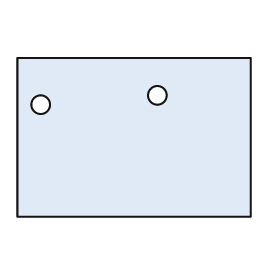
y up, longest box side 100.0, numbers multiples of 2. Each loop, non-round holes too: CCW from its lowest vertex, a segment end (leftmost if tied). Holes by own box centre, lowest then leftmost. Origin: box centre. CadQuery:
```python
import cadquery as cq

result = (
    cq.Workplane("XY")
    .moveTo(-50.0, -34.0)
    .lineTo(50.0, -34.0)
    .lineTo(50.0, 34.0)
    .lineTo(-50.0, 34.0)
    .close()
    .moveTo(-40.0, 14.0)
    .circle(4.0)
    .moveTo(10.0, 18.0)
    .circle(4.0)
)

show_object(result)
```